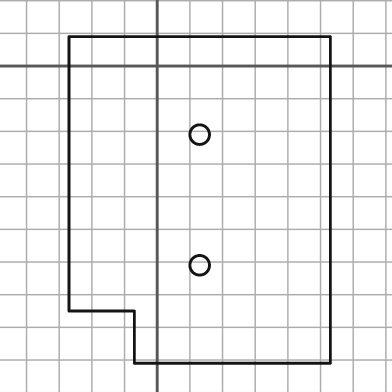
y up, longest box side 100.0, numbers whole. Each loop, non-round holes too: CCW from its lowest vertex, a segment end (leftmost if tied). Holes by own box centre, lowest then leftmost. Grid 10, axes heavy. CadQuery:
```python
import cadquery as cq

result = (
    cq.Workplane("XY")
    .moveTo(-7.0, -91.0)
    .lineTo(53.0, -91.0)
    .lineTo(53.0, 9.0)
    .lineTo(-27.0, 9.0)
    .lineTo(-27.0, -75.0)
    .lineTo(-7.0, -75.0)
    .close()
    .moveTo(13.0, -61.0)
    .circle(3.0)
    .moveTo(13.0, -21.0)
    .circle(3.0)
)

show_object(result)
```